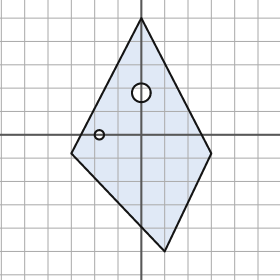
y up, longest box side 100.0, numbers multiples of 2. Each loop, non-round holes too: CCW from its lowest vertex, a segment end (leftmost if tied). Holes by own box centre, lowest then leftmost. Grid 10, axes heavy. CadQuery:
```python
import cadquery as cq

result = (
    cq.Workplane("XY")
    .moveTo(10.0, -50.0)
    .lineTo(30.0, -8.0)
    .lineTo(0.0, 50.0)
    .lineTo(-30.0, -8.0)
    .close()
    .moveTo(-18.0, 0.0)
    .circle(2.0)
    .moveTo(0.0, 18.0)
    .circle(4.0)
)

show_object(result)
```